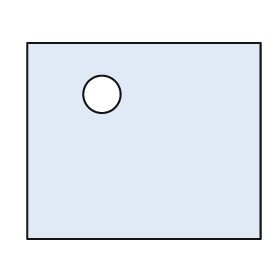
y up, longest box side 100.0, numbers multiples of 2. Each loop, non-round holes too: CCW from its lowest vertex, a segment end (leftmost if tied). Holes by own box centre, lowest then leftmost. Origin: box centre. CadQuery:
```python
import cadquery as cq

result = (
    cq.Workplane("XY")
    .moveTo(-50.0, -42.0)
    .lineTo(50.0, -42.0)
    .lineTo(50.0, 42.0)
    .lineTo(-50.0, 42.0)
    .close()
    .moveTo(-18.0, 20.0)
    .circle(8.0)
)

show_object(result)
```